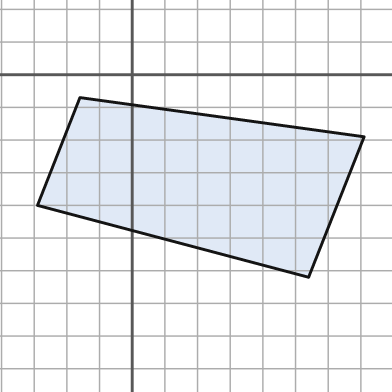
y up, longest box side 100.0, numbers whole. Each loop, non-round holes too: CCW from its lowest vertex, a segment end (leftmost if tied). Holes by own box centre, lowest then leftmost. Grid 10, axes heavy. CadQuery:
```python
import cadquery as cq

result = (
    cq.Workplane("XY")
    .moveTo(54.0, -62.0)
    .lineTo(71.0, -19.0)
    .lineTo(-16.0, -7.0)
    .lineTo(-29.0, -40.0)
    .close()
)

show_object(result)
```